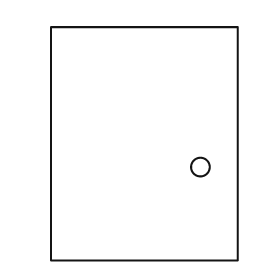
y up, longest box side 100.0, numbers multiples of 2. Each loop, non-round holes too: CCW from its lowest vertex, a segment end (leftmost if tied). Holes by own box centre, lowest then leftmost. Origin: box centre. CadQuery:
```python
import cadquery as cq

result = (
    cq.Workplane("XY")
    .moveTo(-40.0, -50.0)
    .lineTo(40.0, -50.0)
    .lineTo(40.0, 50.0)
    .lineTo(-40.0, 50.0)
    .close()
    .moveTo(24.0, -10.0)
    .circle(4.0)
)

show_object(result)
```